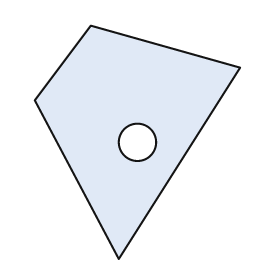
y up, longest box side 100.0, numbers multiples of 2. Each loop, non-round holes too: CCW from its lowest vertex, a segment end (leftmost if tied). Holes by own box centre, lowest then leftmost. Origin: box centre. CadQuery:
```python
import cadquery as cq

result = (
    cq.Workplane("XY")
    .moveTo(-8.0, -50.0)
    .lineTo(44.0, 32.0)
    .lineTo(-20.0, 50.0)
    .lineTo(-44.0, 18.0)
    .close()
    .moveTo(0.0, 0.0)
    .circle(8.0)
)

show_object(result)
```